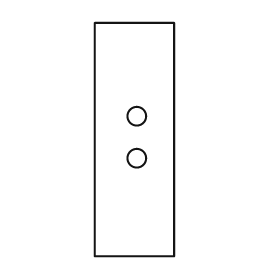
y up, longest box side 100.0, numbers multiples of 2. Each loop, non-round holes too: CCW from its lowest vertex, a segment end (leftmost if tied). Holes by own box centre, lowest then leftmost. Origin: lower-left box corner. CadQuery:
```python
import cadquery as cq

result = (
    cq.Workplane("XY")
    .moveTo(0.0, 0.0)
    .lineTo(34.0, 0.0)
    .lineTo(34.0, 100.0)
    .lineTo(0.0, 100.0)
    .close()
    .moveTo(18.0, 42.0)
    .circle(4.0)
    .moveTo(18.0, 60.0)
    .circle(4.0)
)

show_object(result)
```